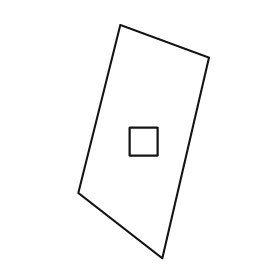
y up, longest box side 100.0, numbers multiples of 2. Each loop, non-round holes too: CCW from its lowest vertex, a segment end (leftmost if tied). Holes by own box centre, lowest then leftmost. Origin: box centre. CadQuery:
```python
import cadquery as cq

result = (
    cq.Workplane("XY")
    .moveTo(8.0, -50.0)
    .lineTo(28.0, 36.0)
    .lineTo(-10.0, 50.0)
    .lineTo(-28.0, -22.0)
    .close()
    .moveTo(-6.0, -6.0)
    .lineTo(6.0, -6.0)
    .lineTo(6.0, 6.0)
    .lineTo(-6.0, 6.0)
    .close()
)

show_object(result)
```